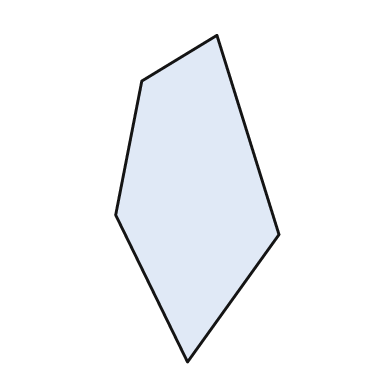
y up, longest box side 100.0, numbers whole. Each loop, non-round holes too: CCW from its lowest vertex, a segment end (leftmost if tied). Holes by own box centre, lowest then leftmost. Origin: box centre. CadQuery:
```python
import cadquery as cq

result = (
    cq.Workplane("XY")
    .moveTo(-3.0, -50.0)
    .lineTo(25.0, -11.0)
    .lineTo(6.0, 50.0)
    .lineTo(-17.0, 36.0)
    .lineTo(-25.0, -5.0)
    .close()
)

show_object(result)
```